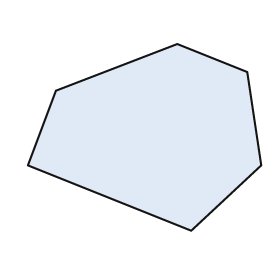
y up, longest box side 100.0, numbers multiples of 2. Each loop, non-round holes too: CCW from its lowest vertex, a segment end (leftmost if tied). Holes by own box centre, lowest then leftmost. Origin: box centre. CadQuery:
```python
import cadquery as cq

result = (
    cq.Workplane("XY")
    .moveTo(20.0, -40.0)
    .lineTo(50.0, -12.0)
    .lineTo(44.0, 28.0)
    .lineTo(14.0, 40.0)
    .lineTo(-38.0, 20.0)
    .lineTo(-50.0, -12.0)
    .close()
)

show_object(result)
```